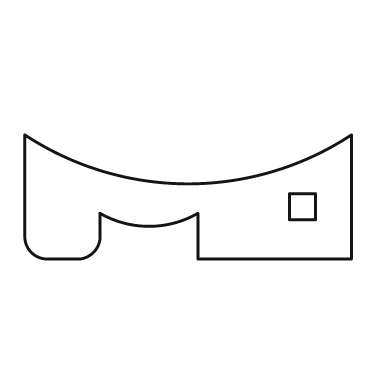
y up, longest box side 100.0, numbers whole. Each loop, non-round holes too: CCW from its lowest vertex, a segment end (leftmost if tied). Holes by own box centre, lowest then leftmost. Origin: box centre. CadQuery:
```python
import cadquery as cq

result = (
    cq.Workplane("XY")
    .moveTo(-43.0, -19.0)
    .lineTo(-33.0, -19.0)
    .threePointArc((-29.0, -17.0), (-27.0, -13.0))
    .lineTo(-27.0, -5.0)
    .threePointArc((-12.0, -9.0), (3.0, -5.0))
    .lineTo(3.0, -19.0)
    .lineTo(50.0, -19.0)
    .lineTo(50.0, 19.0)
    .threePointArc((0.0, 4.0), (-50.0, 19.0))
    .lineTo(-50.0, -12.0)
    .threePointArc((-48.0, -17.0), (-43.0, -19.0))
    .close()
    .moveTo(31.0, -7.0)
    .lineTo(39.0, -7.0)
    .lineTo(39.0, 1.0)
    .lineTo(31.0, 1.0)
    .close()
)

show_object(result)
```